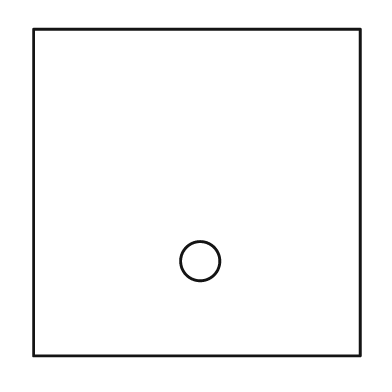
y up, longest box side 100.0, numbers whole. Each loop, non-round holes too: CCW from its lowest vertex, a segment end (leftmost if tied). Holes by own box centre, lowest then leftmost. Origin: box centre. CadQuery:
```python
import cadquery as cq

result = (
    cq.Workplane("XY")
    .moveTo(-50.0, -50.0)
    .lineTo(50.0, -50.0)
    .lineTo(50.0, 50.0)
    .lineTo(-50.0, 50.0)
    .close()
    .moveTo(1.0, -21.0)
    .circle(6.0)
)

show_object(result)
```